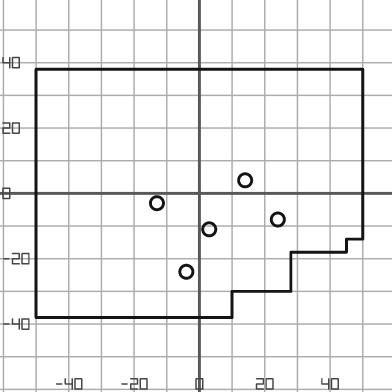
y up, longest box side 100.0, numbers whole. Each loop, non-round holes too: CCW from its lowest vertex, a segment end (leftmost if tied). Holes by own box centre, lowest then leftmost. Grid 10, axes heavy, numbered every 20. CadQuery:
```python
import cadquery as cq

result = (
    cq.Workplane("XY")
    .moveTo(-50.0, -38.0)
    .lineTo(10.0, -38.0)
    .lineTo(10.0, -30.0)
    .lineTo(28.0, -30.0)
    .lineTo(28.0, -18.0)
    .lineTo(45.0, -18.0)
    .lineTo(45.0, -14.0)
    .lineTo(50.0, -14.0)
    .lineTo(50.0, 38.0)
    .lineTo(-50.0, 38.0)
    .close()
    .moveTo(-4.0, -24.0)
    .circle(2.0)
    .moveTo(3.0, -11.0)
    .circle(2.0)
    .moveTo(24.0, -8.0)
    .circle(2.0)
    .moveTo(-13.0, -3.0)
    .circle(2.0)
    .moveTo(14.0, 4.0)
    .circle(2.0)
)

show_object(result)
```